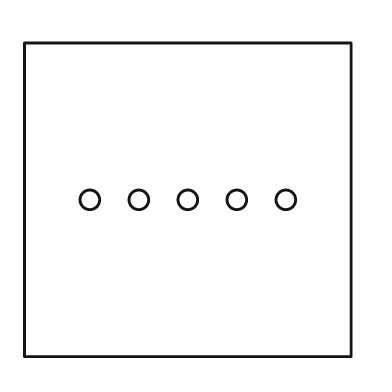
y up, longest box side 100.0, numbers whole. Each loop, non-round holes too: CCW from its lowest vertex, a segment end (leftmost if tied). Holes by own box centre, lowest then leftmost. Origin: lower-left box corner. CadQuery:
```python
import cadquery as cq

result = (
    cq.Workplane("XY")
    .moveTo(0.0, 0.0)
    .lineTo(100.0, 0.0)
    .lineTo(100.0, 96.0)
    .lineTo(0.0, 96.0)
    .close()
    .moveTo(20.0, 48.0)
    .circle(3.0)
    .moveTo(35.0, 48.0)
    .circle(3.0)
    .moveTo(50.0, 48.0)
    .circle(3.0)
    .moveTo(65.0, 48.0)
    .circle(3.0)
    .moveTo(80.0, 48.0)
    .circle(3.0)
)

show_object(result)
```